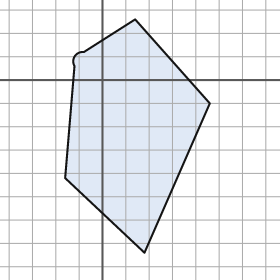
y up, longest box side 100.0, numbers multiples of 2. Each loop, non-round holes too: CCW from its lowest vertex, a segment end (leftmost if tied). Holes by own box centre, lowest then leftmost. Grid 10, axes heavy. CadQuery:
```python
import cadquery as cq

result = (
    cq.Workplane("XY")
    .moveTo(18.0, -74.0)
    .lineTo(46.0, -10.0)
    .lineTo(14.0, 26.0)
    .lineTo(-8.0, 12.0)
    .threePointArc((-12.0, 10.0), (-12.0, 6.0))
    .lineTo(-16.0, -42.0)
    .close()
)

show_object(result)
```